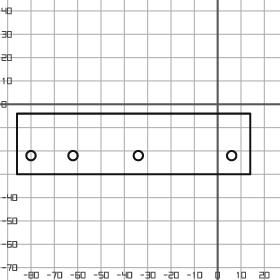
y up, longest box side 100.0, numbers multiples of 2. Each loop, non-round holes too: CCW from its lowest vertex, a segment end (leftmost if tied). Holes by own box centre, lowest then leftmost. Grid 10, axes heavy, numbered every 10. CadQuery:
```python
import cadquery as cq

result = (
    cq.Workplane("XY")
    .moveTo(-86.0, -30.0)
    .lineTo(14.0, -30.0)
    .lineTo(14.0, -4.0)
    .lineTo(-86.0, -4.0)
    .close()
    .moveTo(-80.0, -22.0)
    .circle(2.0)
    .moveTo(-62.0, -22.0)
    .circle(2.0)
    .moveTo(-34.0, -22.0)
    .circle(2.0)
    .moveTo(6.0, -22.0)
    .circle(2.0)
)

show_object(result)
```